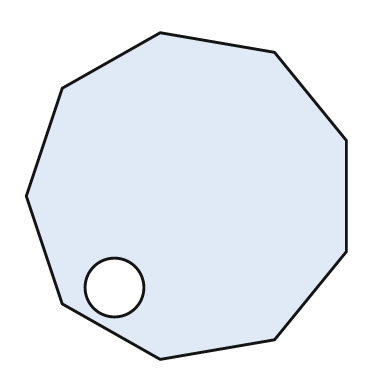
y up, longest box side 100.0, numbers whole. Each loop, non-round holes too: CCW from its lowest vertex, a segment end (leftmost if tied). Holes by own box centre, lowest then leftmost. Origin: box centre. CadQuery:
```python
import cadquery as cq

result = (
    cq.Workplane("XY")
    .moveTo(-8.0, -50.0)
    .lineTo(27.0, -44.0)
    .lineTo(49.0, -17.0)
    .lineTo(49.0, 17.0)
    .lineTo(27.0, 44.0)
    .lineTo(-8.0, 50.0)
    .lineTo(-38.0, 33.0)
    .lineTo(-49.0, 0.0)
    .lineTo(-38.0, -33.0)
    .close()
    .moveTo(-22.0, -28.0)
    .circle(9.0)
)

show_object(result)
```